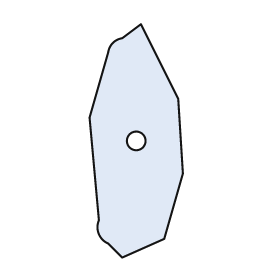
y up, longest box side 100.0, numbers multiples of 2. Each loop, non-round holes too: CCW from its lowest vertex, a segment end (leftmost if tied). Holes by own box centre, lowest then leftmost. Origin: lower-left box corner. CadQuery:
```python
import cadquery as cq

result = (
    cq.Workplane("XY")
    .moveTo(14.0, 0.0)
    .lineTo(32.0, 8.0)
    .lineTo(40.0, 36.0)
    .lineTo(38.0, 68.0)
    .lineTo(22.0, 100.0)
    .lineTo(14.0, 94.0)
    .threePointArc((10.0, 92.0), (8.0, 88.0))
    .lineTo(0.0, 60.0)
    .lineTo(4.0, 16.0)
    .threePointArc((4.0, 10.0), (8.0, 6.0))
    .close()
    .moveTo(20.0, 50.0)
    .circle(4.0)
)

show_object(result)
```